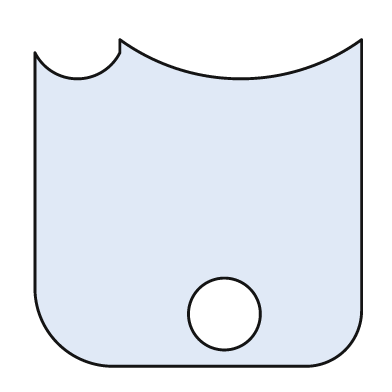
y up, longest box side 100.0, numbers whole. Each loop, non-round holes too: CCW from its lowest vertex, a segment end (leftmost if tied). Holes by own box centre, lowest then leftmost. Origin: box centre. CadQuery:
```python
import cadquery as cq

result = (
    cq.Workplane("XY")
    .moveTo(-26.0, -50.0)
    .lineTo(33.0, -50.0)
    .threePointArc((45.0, -45.0), (50.0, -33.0))
    .lineTo(50.0, 50.0)
    .threePointArc((13.0, 38.0), (-24.0, 50.0))
    .lineTo(-24.0, 46.0)
    .threePointArc((-37.0, 38.0), (-50.0, 46.0))
    .lineTo(-50.0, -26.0)
    .threePointArc((-43.0, -43.0), (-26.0, -50.0))
    .close()
    .moveTo(8.0, -34.0)
    .circle(11.0)
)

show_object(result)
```